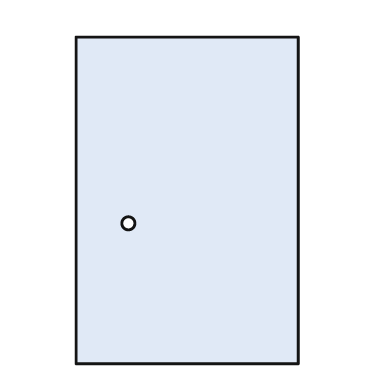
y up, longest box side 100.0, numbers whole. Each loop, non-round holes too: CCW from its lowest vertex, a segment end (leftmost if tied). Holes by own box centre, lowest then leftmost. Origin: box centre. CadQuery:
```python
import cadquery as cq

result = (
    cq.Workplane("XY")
    .moveTo(-34.0, -50.0)
    .lineTo(34.0, -50.0)
    .lineTo(34.0, 50.0)
    .lineTo(-34.0, 50.0)
    .close()
    .moveTo(-18.0, -7.0)
    .circle(2.0)
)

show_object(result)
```